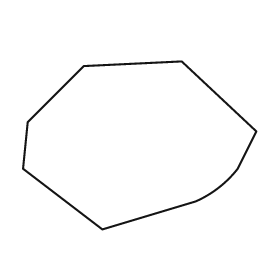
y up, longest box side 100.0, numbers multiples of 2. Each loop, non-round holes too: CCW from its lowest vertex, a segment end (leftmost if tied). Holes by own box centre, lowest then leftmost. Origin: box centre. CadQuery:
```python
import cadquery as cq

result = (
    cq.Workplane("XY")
    .moveTo(-16.0, -36.0)
    .lineTo(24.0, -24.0)
    .threePointArc((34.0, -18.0), (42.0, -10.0))
    .lineTo(50.0, 6.0)
    .lineTo(18.0, 36.0)
    .lineTo(-24.0, 34.0)
    .lineTo(-48.0, 10.0)
    .lineTo(-50.0, -10.0)
    .close()
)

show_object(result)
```